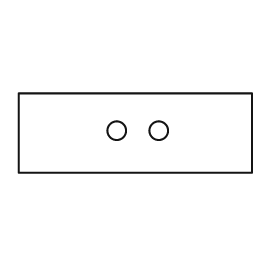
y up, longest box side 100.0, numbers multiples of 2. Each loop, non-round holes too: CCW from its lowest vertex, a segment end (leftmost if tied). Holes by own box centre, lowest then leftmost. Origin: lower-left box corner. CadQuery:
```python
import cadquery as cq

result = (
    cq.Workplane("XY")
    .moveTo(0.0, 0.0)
    .lineTo(100.0, 0.0)
    .lineTo(100.0, 34.0)
    .lineTo(0.0, 34.0)
    .close()
    .moveTo(42.0, 18.0)
    .circle(4.0)
    .moveTo(60.0, 18.0)
    .circle(4.0)
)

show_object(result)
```